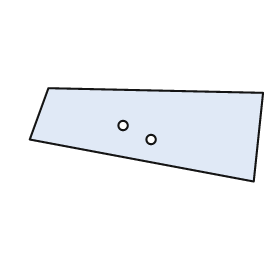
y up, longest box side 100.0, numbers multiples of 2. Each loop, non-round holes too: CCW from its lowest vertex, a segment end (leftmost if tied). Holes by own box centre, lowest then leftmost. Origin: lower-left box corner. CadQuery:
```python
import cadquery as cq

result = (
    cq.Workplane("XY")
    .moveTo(96.0, 0.0)
    .lineTo(100.0, 38.0)
    .lineTo(8.0, 40.0)
    .lineTo(0.0, 18.0)
    .close()
    .moveTo(52.0, 18.0)
    .circle(2.0)
    .moveTo(40.0, 24.0)
    .circle(2.0)
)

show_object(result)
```